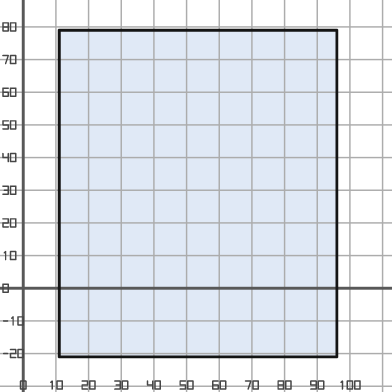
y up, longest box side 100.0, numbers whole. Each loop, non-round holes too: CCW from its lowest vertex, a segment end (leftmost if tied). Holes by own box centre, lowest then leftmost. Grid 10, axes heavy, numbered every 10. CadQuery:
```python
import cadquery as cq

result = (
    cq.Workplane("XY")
    .moveTo(11.0, -21.0)
    .lineTo(96.0, -21.0)
    .lineTo(96.0, 79.0)
    .lineTo(11.0, 79.0)
    .close()
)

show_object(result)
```